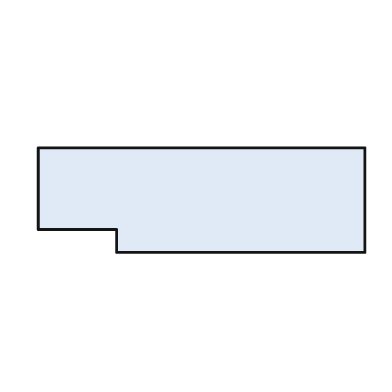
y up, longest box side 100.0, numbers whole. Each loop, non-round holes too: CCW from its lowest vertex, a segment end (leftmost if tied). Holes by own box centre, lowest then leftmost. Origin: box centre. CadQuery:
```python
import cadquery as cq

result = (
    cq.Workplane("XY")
    .moveTo(-26.0, -16.0)
    .lineTo(50.0, -16.0)
    .lineTo(50.0, 16.0)
    .lineTo(-50.0, 16.0)
    .lineTo(-50.0, -9.0)
    .lineTo(-26.0, -9.0)
    .close()
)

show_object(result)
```